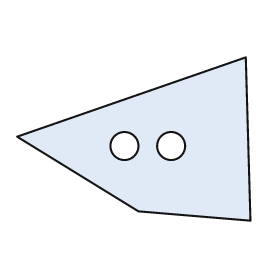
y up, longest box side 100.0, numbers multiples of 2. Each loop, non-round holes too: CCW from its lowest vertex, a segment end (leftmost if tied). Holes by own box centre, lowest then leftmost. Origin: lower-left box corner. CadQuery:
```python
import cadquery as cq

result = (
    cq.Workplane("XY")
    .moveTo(100.0, 0.0)
    .lineTo(98.0, 70.0)
    .lineTo(0.0, 36.0)
    .lineTo(52.0, 4.0)
    .close()
    .moveTo(46.0, 32.0)
    .circle(6.0)
    .moveTo(66.0, 32.0)
    .circle(6.0)
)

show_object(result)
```